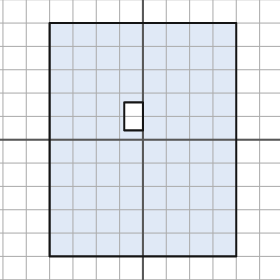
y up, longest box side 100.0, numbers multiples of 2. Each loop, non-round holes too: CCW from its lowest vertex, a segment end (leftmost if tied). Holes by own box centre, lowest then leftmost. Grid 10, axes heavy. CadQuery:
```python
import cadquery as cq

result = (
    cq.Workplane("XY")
    .moveTo(-40.0, -50.0)
    .lineTo(40.0, -50.0)
    .lineTo(40.0, 50.0)
    .lineTo(-40.0, 50.0)
    .close()
    .moveTo(-8.0, 4.0)
    .lineTo(0.0, 4.0)
    .lineTo(0.0, 16.0)
    .lineTo(-8.0, 16.0)
    .close()
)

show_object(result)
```